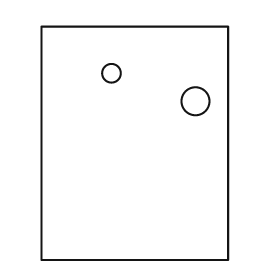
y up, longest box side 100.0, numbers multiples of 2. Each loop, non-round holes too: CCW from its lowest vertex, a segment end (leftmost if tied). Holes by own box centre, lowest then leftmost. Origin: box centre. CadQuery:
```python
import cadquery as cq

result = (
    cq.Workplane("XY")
    .moveTo(-40.0, -50.0)
    .lineTo(40.0, -50.0)
    .lineTo(40.0, 50.0)
    .lineTo(-40.0, 50.0)
    .close()
    .moveTo(26.0, 18.0)
    .circle(6.0)
    .moveTo(-10.0, 30.0)
    .circle(4.0)
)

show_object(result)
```